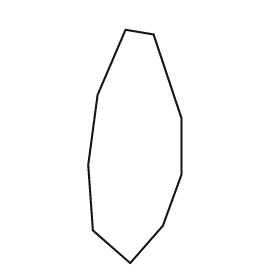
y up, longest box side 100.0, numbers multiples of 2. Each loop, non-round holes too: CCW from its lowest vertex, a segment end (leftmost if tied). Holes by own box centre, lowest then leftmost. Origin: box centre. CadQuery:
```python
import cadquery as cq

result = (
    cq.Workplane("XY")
    .moveTo(-2.0, -50.0)
    .lineTo(12.0, -34.0)
    .lineTo(20.0, -12.0)
    .lineTo(20.0, 12.0)
    .lineTo(8.0, 48.0)
    .lineTo(-4.0, 50.0)
    .lineTo(-16.0, 22.0)
    .lineTo(-20.0, -8.0)
    .lineTo(-18.0, -36.0)
    .close()
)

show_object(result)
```